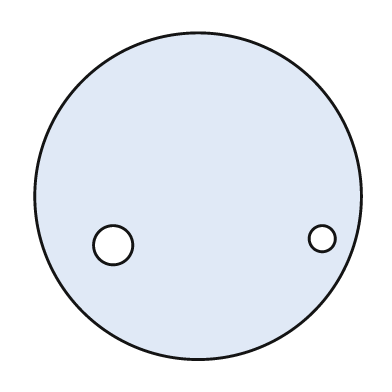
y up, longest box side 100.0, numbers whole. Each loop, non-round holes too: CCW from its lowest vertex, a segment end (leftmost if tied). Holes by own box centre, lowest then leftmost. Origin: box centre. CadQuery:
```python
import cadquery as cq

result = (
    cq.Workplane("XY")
    .moveTo(0.0, 0.0)
    .circle(50.0)
    .moveTo(-26.0, -15.0)
    .circle(6.0)
    .moveTo(38.0, -13.0)
    .circle(4.0)
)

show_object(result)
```